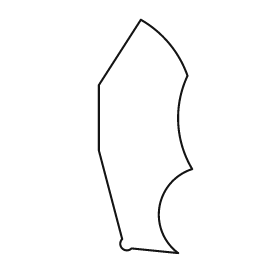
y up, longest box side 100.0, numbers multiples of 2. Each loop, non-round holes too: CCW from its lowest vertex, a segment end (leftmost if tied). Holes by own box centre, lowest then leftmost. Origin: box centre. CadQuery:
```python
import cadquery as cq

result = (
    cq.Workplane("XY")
    .moveTo(14.0, -50.0)
    .threePointArc((6.0, -30.0), (20.0, -14.0))
    .threePointArc((14.0, 6.0), (18.0, 26.0))
    .threePointArc((10.0, 40.0), (-2.0, 50.0))
    .lineTo(-20.0, 22.0)
    .lineTo(-20.0, -6.0)
    .lineTo(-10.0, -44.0)
    .threePointArc((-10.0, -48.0), (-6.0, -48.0))
    .close()
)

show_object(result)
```